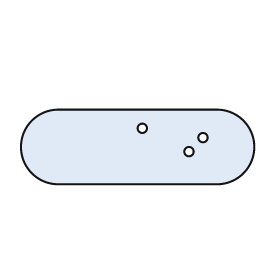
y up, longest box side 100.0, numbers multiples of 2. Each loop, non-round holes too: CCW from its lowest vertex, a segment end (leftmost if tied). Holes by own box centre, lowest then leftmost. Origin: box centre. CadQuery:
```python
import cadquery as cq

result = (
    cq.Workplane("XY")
    .moveTo(-34.0, -16.0)
    .lineTo(34.0, -16.0)
    .threePointArc((50.0, 0.0), (34.0, 16.0))
    .lineTo(-34.0, 16.0)
    .threePointArc((-50.0, 0.0), (-34.0, -16.0))
    .close()
    .moveTo(22.0, -2.0)
    .circle(2.0)
    .moveTo(28.0, 4.0)
    .circle(2.0)
    .moveTo(2.0, 8.0)
    .circle(2.0)
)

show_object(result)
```